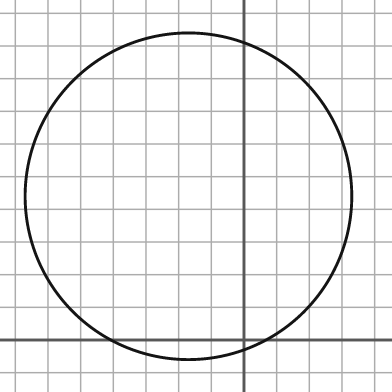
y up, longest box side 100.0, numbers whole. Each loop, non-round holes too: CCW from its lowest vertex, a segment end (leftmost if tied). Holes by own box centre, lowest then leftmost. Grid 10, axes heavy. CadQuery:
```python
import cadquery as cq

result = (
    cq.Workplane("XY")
    .moveTo(-17.0, 44.0)
    .circle(50.0)
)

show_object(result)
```